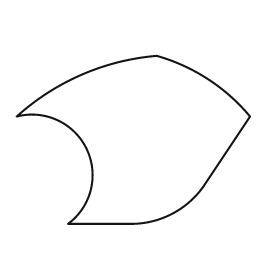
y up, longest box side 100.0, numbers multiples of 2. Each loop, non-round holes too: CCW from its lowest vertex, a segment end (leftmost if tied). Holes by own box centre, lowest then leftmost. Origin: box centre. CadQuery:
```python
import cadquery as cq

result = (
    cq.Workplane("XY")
    .moveTo(-28.0, -36.0)
    .lineTo(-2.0, -36.0)
    .threePointArc((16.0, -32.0), (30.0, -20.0))
    .lineTo(50.0, 10.0)
    .threePointArc((32.0, 26.0), (10.0, 36.0))
    .threePointArc((-22.0, 28.0), (-50.0, 10.0))
    .threePointArc((-20.0, -4.0), (-28.0, -36.0))
    .close()
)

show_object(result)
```